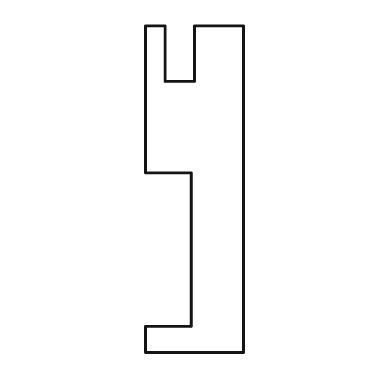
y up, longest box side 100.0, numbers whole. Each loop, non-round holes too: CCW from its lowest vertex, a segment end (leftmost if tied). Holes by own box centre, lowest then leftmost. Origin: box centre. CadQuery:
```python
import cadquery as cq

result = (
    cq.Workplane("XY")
    .moveTo(-15.0, -50.0)
    .lineTo(15.0, -50.0)
    .lineTo(15.0, 50.0)
    .lineTo(0.0, 50.0)
    .lineTo(0.0, 33.0)
    .lineTo(-9.0, 33.0)
    .lineTo(-9.0, 50.0)
    .lineTo(-15.0, 50.0)
    .lineTo(-15.0, 5.0)
    .lineTo(-1.0, 5.0)
    .lineTo(-1.0, -42.0)
    .lineTo(-15.0, -42.0)
    .close()
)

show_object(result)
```